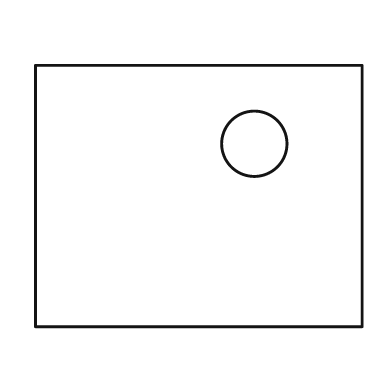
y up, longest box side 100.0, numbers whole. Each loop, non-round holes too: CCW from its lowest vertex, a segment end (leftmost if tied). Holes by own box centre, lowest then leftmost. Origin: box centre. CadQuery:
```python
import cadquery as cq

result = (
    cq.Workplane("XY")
    .moveTo(-50.0, -40.0)
    .lineTo(50.0, -40.0)
    .lineTo(50.0, 40.0)
    .lineTo(-50.0, 40.0)
    .close()
    .moveTo(17.0, 16.0)
    .circle(10.0)
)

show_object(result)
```